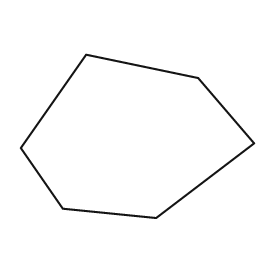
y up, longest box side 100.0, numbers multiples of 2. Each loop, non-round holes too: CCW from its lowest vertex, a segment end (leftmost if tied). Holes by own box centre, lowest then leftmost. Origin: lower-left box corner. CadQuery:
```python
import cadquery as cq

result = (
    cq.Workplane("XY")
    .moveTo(58.0, 0.0)
    .lineTo(100.0, 32.0)
    .lineTo(76.0, 60.0)
    .lineTo(28.0, 70.0)
    .lineTo(0.0, 30.0)
    .lineTo(18.0, 4.0)
    .close()
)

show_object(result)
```